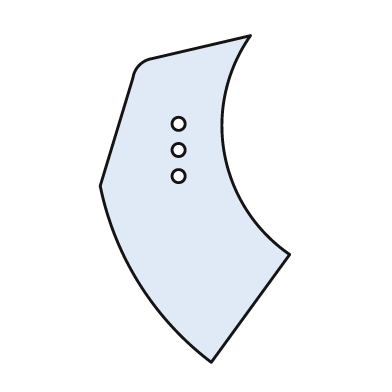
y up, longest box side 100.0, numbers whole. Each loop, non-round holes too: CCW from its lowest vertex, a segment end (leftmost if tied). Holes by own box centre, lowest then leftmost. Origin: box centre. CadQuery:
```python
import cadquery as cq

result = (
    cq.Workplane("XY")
    .moveTo(5.0, -50.0)
    .lineTo(29.0, -17.0)
    .threePointArc((9.0, 14.0), (17.0, 50.0))
    .lineTo(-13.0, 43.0)
    .threePointArc((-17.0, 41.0), (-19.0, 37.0))
    .lineTo(-29.0, 4.0)
    .threePointArc((-17.0, -26.0), (5.0, -50.0))
    .close()
    .moveTo(-5.0, 7.0)
    .circle(2.0)
    .moveTo(-5.0, 15.0)
    .circle(2.0)
    .moveTo(-5.0, 23.0)
    .circle(2.0)
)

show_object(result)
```